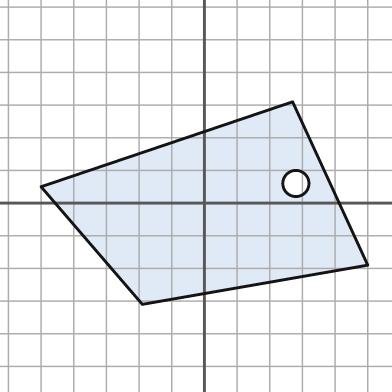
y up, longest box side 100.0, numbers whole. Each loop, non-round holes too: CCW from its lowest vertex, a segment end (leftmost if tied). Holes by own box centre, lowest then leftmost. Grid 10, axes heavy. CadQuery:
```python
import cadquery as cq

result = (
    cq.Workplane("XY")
    .moveTo(-19.0, -31.0)
    .lineTo(50.0, -19.0)
    .lineTo(27.0, 31.0)
    .lineTo(-50.0, 5.0)
    .close()
    .moveTo(28.0, 6.0)
    .circle(4.0)
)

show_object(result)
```